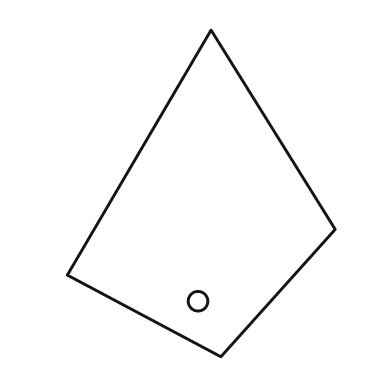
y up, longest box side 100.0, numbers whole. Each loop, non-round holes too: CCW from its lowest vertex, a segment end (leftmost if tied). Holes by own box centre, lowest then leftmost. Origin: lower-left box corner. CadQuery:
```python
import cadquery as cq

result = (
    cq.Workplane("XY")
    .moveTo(47.0, 0.0)
    .lineTo(82.0, 39.0)
    .lineTo(44.0, 100.0)
    .lineTo(0.0, 25.0)
    .close()
    .moveTo(40.0, 17.0)
    .circle(3.0)
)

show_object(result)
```